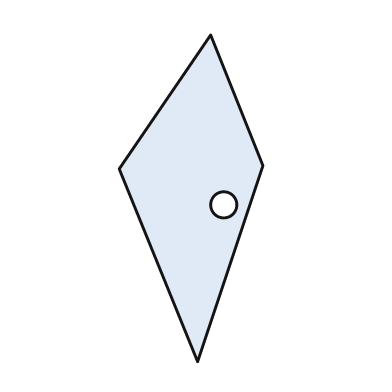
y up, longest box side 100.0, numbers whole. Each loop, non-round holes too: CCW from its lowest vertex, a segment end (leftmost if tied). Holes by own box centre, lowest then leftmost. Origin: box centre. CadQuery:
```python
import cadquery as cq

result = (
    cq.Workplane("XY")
    .moveTo(2.0, -50.0)
    .lineTo(22.0, 10.0)
    .lineTo(6.0, 50.0)
    .lineTo(-22.0, 9.0)
    .close()
    .moveTo(10.0, -2.0)
    .circle(4.0)
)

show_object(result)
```